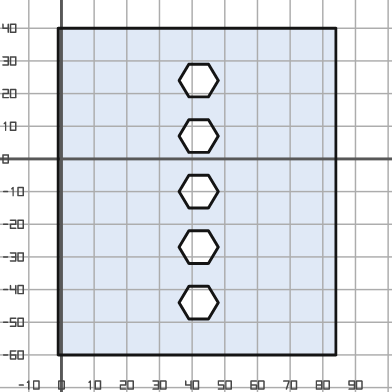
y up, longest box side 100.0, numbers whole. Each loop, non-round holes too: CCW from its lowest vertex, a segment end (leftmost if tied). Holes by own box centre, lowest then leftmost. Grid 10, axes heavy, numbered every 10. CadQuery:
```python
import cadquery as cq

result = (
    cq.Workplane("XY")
    .moveTo(-1.0, -60.0)
    .lineTo(84.0, -60.0)
    .lineTo(84.0, 40.0)
    .lineTo(-1.0, 40.0)
    .close()
    .moveTo(39.0, -49.0)
    .lineTo(45.0, -49.0)
    .lineTo(48.0, -44.0)
    .lineTo(45.0, -39.0)
    .lineTo(39.0, -39.0)
    .lineTo(36.0, -44.0)
    .close()
    .moveTo(39.0, -32.0)
    .lineTo(45.0, -32.0)
    .lineTo(48.0, -27.0)
    .lineTo(45.0, -22.0)
    .lineTo(39.0, -22.0)
    .lineTo(36.0, -27.0)
    .close()
    .moveTo(39.0, -15.0)
    .lineTo(45.0, -15.0)
    .lineTo(48.0, -10.0)
    .lineTo(45.0, -5.0)
    .lineTo(39.0, -5.0)
    .lineTo(36.0, -10.0)
    .close()
    .moveTo(39.0, 2.0)
    .lineTo(45.0, 2.0)
    .lineTo(48.0, 7.0)
    .lineTo(45.0, 12.0)
    .lineTo(39.0, 12.0)
    .lineTo(36.0, 7.0)
    .close()
    .moveTo(39.0, 19.0)
    .lineTo(45.0, 19.0)
    .lineTo(48.0, 24.0)
    .lineTo(45.0, 29.0)
    .lineTo(39.0, 29.0)
    .lineTo(36.0, 24.0)
    .close()
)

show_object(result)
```